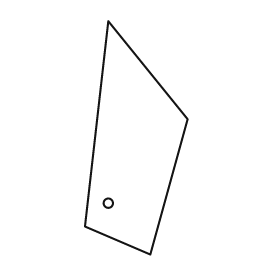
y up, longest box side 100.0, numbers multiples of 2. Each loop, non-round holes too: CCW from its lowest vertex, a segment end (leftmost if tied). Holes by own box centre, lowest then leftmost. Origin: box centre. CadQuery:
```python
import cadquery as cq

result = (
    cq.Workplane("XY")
    .moveTo(6.0, -50.0)
    .lineTo(22.0, 8.0)
    .lineTo(-12.0, 50.0)
    .lineTo(-22.0, -38.0)
    .close()
    .moveTo(-12.0, -28.0)
    .circle(2.0)
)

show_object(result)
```